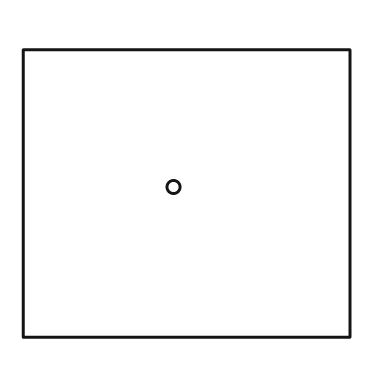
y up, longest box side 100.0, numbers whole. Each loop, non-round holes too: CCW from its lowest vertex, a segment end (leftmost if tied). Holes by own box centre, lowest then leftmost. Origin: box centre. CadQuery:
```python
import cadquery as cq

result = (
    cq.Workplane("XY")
    .moveTo(-50.0, -44.0)
    .lineTo(50.0, -44.0)
    .lineTo(50.0, 44.0)
    .lineTo(-50.0, 44.0)
    .close()
    .moveTo(-4.0, 2.0)
    .circle(2.0)
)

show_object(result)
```